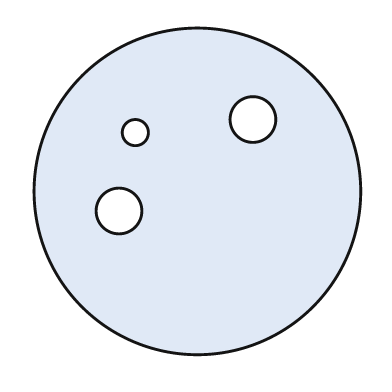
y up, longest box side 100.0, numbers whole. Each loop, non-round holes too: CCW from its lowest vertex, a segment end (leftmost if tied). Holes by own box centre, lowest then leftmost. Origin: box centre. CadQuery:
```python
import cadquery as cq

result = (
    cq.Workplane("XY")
    .moveTo(0.0, 0.0)
    .circle(50.0)
    .moveTo(-24.0, -6.0)
    .circle(7.0)
    .moveTo(-19.0, 18.0)
    .circle(4.0)
    .moveTo(17.0, 22.0)
    .circle(7.0)
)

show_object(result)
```